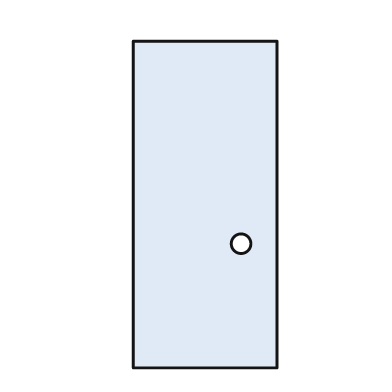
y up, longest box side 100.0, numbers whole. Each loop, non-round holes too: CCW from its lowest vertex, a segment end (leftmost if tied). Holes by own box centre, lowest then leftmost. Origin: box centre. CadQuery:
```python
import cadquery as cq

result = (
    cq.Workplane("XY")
    .moveTo(-22.0, -50.0)
    .lineTo(22.0, -50.0)
    .lineTo(22.0, 50.0)
    .lineTo(-22.0, 50.0)
    .close()
    .moveTo(11.0, -12.0)
    .circle(3.0)
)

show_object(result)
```